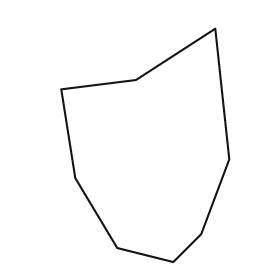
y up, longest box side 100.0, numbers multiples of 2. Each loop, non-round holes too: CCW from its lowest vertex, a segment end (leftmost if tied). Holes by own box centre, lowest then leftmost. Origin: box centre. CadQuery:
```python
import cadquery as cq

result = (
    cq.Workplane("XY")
    .moveTo(12.0, -50.0)
    .lineTo(24.0, -38.0)
    .lineTo(36.0, -6.0)
    .lineTo(30.0, 50.0)
    .lineTo(-4.0, 28.0)
    .lineTo(-36.0, 24.0)
    .lineTo(-30.0, -14.0)
    .lineTo(-12.0, -44.0)
    .close()
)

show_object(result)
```